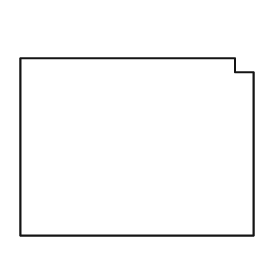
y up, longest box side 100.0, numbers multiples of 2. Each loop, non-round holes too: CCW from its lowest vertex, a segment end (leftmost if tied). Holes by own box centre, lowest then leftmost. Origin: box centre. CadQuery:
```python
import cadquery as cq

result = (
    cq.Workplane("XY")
    .moveTo(-50.0, -38.0)
    .lineTo(50.0, -38.0)
    .lineTo(50.0, 32.0)
    .lineTo(42.0, 32.0)
    .lineTo(42.0, 38.0)
    .lineTo(-50.0, 38.0)
    .close()
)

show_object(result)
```